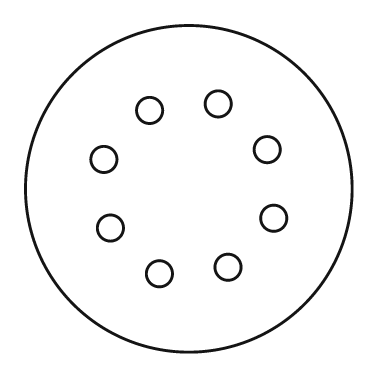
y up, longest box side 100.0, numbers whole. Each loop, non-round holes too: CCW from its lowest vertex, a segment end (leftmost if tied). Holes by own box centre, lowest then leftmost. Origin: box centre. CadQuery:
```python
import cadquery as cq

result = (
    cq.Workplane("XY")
    .moveTo(0.0, 0.0)
    .circle(50.0)
    .moveTo(-9.0, -26.0)
    .circle(4.0)
    .moveTo(12.0, -24.0)
    .circle(4.0)
    .moveTo(-24.0, -12.0)
    .circle(4.0)
    .moveTo(26.0, -9.0)
    .circle(4.0)
    .moveTo(-26.0, 9.0)
    .circle(4.0)
    .moveTo(24.0, 12.0)
    .circle(4.0)
    .moveTo(-12.0, 24.0)
    .circle(4.0)
    .moveTo(9.0, 26.0)
    .circle(4.0)
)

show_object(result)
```